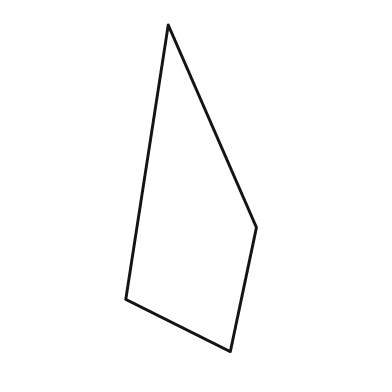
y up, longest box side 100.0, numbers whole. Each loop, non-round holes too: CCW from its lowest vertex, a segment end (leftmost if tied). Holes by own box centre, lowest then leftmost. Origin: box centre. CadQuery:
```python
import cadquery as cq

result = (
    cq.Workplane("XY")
    .moveTo(12.0, -50.0)
    .lineTo(20.0, -12.0)
    .lineTo(-7.0, 50.0)
    .lineTo(-20.0, -34.0)
    .close()
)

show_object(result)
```